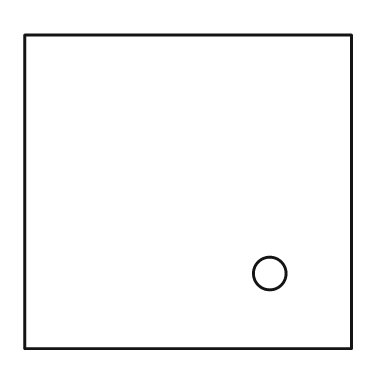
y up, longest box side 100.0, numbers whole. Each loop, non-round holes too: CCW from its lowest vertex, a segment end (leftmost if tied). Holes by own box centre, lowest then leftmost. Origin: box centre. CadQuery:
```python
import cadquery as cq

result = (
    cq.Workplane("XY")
    .moveTo(-50.0, -48.0)
    .lineTo(50.0, -48.0)
    .lineTo(50.0, 48.0)
    .lineTo(-50.0, 48.0)
    .close()
    .moveTo(25.0, -25.0)
    .circle(5.0)
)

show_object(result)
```